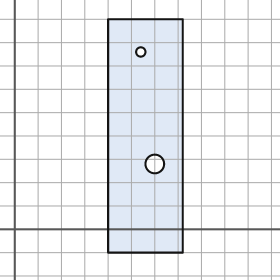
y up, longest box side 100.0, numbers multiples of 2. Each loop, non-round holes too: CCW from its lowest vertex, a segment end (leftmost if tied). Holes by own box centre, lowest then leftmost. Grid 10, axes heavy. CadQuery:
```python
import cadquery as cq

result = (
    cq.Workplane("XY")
    .moveTo(40.0, -10.0)
    .lineTo(72.0, -10.0)
    .lineTo(72.0, 90.0)
    .lineTo(40.0, 90.0)
    .close()
    .moveTo(60.0, 28.0)
    .circle(4.0)
    .moveTo(54.0, 76.0)
    .circle(2.0)
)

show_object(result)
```